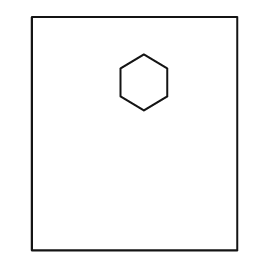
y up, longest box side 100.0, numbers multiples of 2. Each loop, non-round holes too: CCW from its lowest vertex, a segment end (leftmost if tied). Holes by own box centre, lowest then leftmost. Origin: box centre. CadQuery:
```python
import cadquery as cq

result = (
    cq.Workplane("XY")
    .moveTo(-44.0, -50.0)
    .lineTo(44.0, -50.0)
    .lineTo(44.0, 50.0)
    .lineTo(-44.0, 50.0)
    .close()
    .moveTo(4.0, 10.0)
    .lineTo(14.0, 16.0)
    .lineTo(14.0, 28.0)
    .lineTo(4.0, 34.0)
    .lineTo(-6.0, 28.0)
    .lineTo(-6.0, 16.0)
    .close()
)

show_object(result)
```